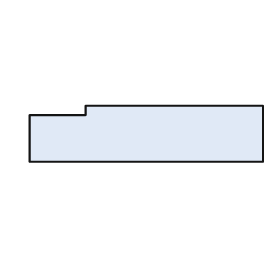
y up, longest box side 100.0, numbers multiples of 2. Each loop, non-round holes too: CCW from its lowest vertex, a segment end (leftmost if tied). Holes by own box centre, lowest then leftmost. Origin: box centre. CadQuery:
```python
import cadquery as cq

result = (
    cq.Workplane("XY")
    .moveTo(-50.0, -12.0)
    .lineTo(50.0, -12.0)
    .lineTo(50.0, 12.0)
    .lineTo(-26.0, 12.0)
    .lineTo(-26.0, 8.0)
    .lineTo(-50.0, 8.0)
    .close()
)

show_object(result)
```